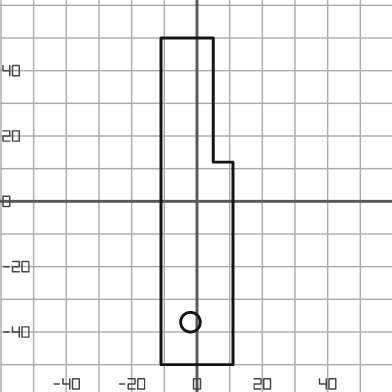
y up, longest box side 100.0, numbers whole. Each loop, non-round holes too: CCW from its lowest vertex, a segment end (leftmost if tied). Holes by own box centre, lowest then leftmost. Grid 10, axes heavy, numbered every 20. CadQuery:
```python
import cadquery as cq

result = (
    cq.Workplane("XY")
    .moveTo(-11.0, -50.0)
    .lineTo(11.0, -50.0)
    .lineTo(11.0, 12.0)
    .lineTo(5.0, 12.0)
    .lineTo(5.0, 50.0)
    .lineTo(-11.0, 50.0)
    .close()
    .moveTo(-2.0, -37.0)
    .circle(3.0)
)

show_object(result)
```